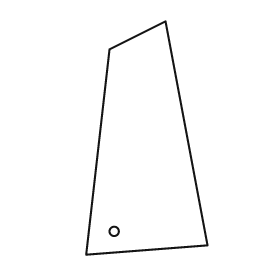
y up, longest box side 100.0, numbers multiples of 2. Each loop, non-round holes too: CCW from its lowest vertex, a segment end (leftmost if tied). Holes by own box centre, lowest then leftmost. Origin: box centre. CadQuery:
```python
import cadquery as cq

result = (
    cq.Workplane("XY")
    .moveTo(-26.0, -50.0)
    .lineTo(26.0, -46.0)
    .lineTo(8.0, 50.0)
    .lineTo(-16.0, 38.0)
    .close()
    .moveTo(-14.0, -40.0)
    .circle(2.0)
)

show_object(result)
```